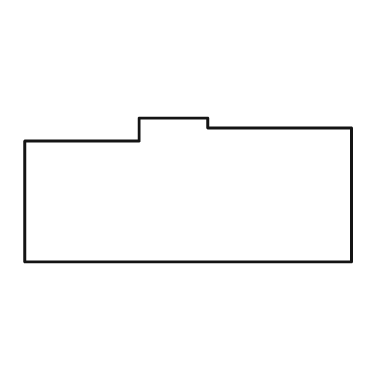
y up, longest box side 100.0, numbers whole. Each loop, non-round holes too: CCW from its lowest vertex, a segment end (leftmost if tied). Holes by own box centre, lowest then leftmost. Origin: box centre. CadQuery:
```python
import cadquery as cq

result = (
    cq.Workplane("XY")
    .moveTo(-50.0, -22.0)
    .lineTo(50.0, -22.0)
    .lineTo(50.0, 19.0)
    .lineTo(6.0, 19.0)
    .lineTo(6.0, 22.0)
    .lineTo(-15.0, 22.0)
    .lineTo(-15.0, 15.0)
    .lineTo(-50.0, 15.0)
    .close()
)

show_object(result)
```